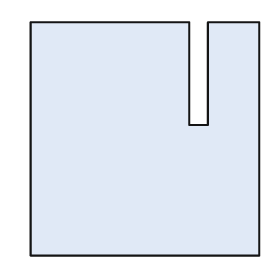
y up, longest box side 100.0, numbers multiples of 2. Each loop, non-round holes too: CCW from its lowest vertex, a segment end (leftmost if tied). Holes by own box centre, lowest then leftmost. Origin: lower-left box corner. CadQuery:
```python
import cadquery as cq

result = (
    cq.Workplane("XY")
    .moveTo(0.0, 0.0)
    .lineTo(98.0, 0.0)
    .lineTo(98.0, 100.0)
    .lineTo(76.0, 100.0)
    .lineTo(76.0, 56.0)
    .lineTo(68.0, 56.0)
    .lineTo(68.0, 100.0)
    .lineTo(0.0, 100.0)
    .close()
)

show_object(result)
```